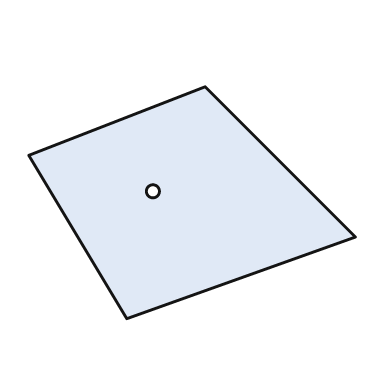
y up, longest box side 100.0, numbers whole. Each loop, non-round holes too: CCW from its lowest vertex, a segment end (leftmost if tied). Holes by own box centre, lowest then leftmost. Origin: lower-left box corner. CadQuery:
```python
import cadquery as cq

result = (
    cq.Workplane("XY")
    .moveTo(30.0, 0.0)
    .lineTo(100.0, 25.0)
    .lineTo(54.0, 71.0)
    .lineTo(0.0, 50.0)
    .close()
    .moveTo(38.0, 39.0)
    .circle(2.0)
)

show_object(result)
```